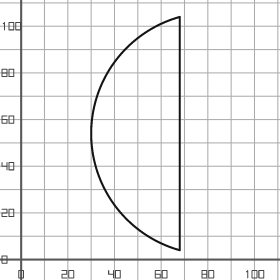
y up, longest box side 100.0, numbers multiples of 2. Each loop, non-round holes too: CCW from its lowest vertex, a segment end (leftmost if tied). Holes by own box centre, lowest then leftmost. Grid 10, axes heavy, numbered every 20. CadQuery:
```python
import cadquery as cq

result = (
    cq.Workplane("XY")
    .moveTo(68.0, 4.0)
    .lineTo(68.0, 104.0)
    .threePointArc((30.0, 54.0), (68.0, 4.0))
    .close()
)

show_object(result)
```